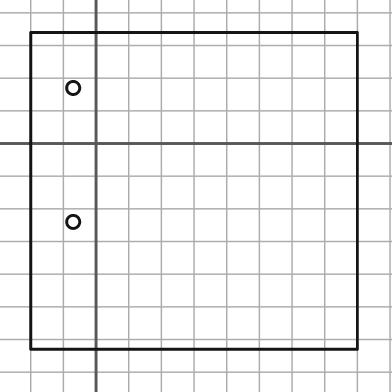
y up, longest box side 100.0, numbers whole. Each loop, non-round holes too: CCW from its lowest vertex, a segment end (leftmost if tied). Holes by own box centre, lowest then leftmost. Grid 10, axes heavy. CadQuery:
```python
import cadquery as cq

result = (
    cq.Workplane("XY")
    .moveTo(-20.0, -63.0)
    .lineTo(80.0, -63.0)
    .lineTo(80.0, 34.0)
    .lineTo(-20.0, 34.0)
    .close()
    .moveTo(-7.0, -24.0)
    .circle(2.0)
    .moveTo(-7.0, 17.0)
    .circle(2.0)
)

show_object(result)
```